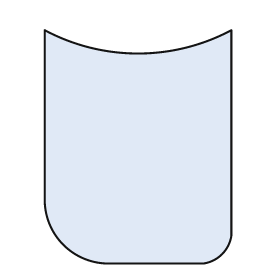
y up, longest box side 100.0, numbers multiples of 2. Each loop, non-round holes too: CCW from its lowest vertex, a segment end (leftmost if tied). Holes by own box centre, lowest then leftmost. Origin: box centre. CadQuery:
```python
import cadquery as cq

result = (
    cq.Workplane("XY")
    .moveTo(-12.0, -50.0)
    .lineTo(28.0, -50.0)
    .threePointArc((36.0, -46.0), (40.0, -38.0))
    .lineTo(40.0, 50.0)
    .threePointArc((0.0, 40.0), (-40.0, 50.0))
    .lineTo(-40.0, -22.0)
    .threePointArc((-32.0, -42.0), (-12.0, -50.0))
    .close()
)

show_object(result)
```